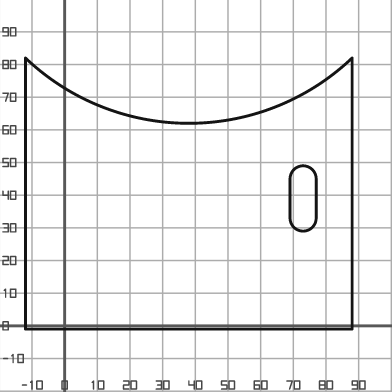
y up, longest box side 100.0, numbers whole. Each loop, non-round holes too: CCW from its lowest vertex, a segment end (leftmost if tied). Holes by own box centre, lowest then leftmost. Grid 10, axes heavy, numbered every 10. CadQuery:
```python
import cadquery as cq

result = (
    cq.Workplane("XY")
    .moveTo(-12.0, -1.0)
    .lineTo(88.0, -1.0)
    .lineTo(88.0, 82.0)
    .threePointArc((38.0, 62.0), (-12.0, 82.0))
    .close()
    .moveTo(69.0, 33.0)
    .threePointArc((73.0, 29.0), (77.0, 33.0))
    .lineTo(77.0, 45.0)
    .threePointArc((73.0, 49.0), (69.0, 45.0))
    .close()
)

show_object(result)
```